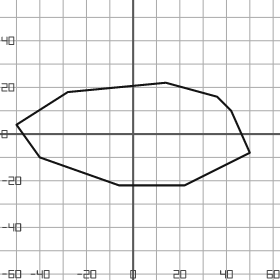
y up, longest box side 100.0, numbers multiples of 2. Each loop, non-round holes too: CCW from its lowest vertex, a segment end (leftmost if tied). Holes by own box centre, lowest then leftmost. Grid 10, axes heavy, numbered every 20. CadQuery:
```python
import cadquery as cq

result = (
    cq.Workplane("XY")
    .moveTo(-6.0, -22.0)
    .lineTo(22.0, -22.0)
    .lineTo(50.0, -8.0)
    .lineTo(42.0, 10.0)
    .lineTo(36.0, 16.0)
    .lineTo(14.0, 22.0)
    .lineTo(-28.0, 18.0)
    .lineTo(-50.0, 4.0)
    .lineTo(-40.0, -10.0)
    .close()
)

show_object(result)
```